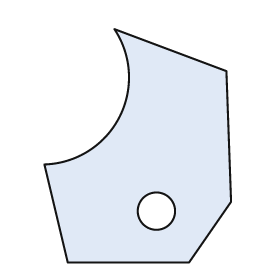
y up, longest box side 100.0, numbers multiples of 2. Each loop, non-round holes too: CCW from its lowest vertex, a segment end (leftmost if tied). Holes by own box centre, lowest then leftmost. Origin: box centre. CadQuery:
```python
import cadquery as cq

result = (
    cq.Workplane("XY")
    .moveTo(-30.0, -50.0)
    .lineTo(22.0, -50.0)
    .lineTo(40.0, -24.0)
    .lineTo(38.0, 32.0)
    .lineTo(-10.0, 50.0)
    .threePointArc((-8.0, 12.0), (-40.0, -8.0))
    .close()
    .moveTo(8.0, -28.0)
    .circle(8.0)
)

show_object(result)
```